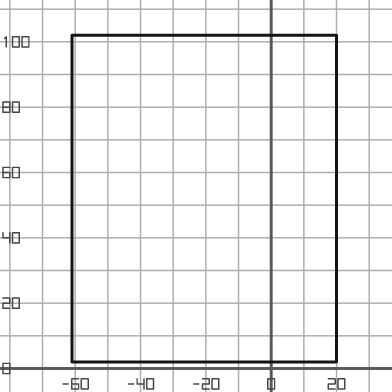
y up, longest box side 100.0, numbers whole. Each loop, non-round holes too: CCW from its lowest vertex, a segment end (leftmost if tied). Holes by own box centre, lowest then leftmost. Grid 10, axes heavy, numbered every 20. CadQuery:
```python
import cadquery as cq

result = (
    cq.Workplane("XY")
    .moveTo(-61.0, 2.0)
    .lineTo(20.0, 2.0)
    .lineTo(20.0, 102.0)
    .lineTo(-61.0, 102.0)
    .close()
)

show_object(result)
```